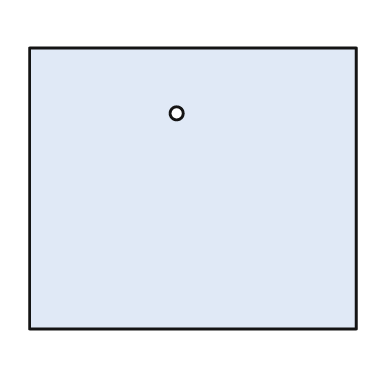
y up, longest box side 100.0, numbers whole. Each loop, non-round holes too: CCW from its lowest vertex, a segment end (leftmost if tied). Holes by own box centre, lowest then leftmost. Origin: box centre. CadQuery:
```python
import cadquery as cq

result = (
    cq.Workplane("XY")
    .moveTo(-50.0, -43.0)
    .lineTo(50.0, -43.0)
    .lineTo(50.0, 43.0)
    .lineTo(-50.0, 43.0)
    .close()
    .moveTo(-5.0, 23.0)
    .circle(2.0)
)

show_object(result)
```